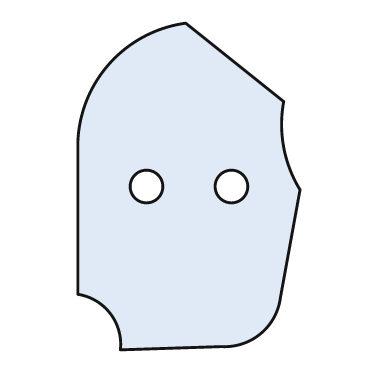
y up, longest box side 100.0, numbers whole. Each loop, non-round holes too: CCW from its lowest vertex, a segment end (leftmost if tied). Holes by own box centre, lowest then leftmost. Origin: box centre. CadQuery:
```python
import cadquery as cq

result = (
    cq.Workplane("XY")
    .moveTo(-21.0, -50.0)
    .lineTo(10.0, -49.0)
    .threePointArc((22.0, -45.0), (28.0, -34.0))
    .lineTo(34.0, -1.0)
    .threePointArc((29.0, 12.0), (29.0, 26.0))
    .lineTo(-1.0, 50.0)
    .threePointArc((-24.0, 38.0), (-34.0, 14.0))
    .lineTo(-34.0, -33.0)
    .threePointArc((-24.0, -39.0), (-21.0, -50.0))
    .close()
    .moveTo(-13.0, 0.0)
    .circle(5.0)
    .moveTo(13.0, 0.0)
    .circle(5.0)
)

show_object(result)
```